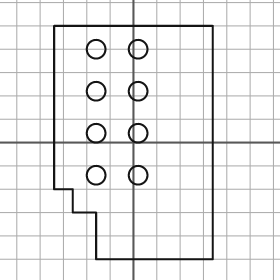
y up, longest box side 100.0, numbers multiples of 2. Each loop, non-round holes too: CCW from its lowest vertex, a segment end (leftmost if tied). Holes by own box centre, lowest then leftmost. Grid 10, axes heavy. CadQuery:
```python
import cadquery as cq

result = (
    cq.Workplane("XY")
    .moveTo(-16.0, -50.0)
    .lineTo(34.0, -50.0)
    .lineTo(34.0, 50.0)
    .lineTo(-34.0, 50.0)
    .lineTo(-34.0, -20.0)
    .lineTo(-26.0, -20.0)
    .lineTo(-26.0, -30.0)
    .lineTo(-16.0, -30.0)
    .close()
    .moveTo(-16.0, -14.0)
    .circle(4.0)
    .moveTo(2.0, -14.0)
    .circle(4.0)
    .moveTo(-16.0, 4.0)
    .circle(4.0)
    .moveTo(2.0, 4.0)
    .circle(4.0)
    .moveTo(-16.0, 22.0)
    .circle(4.0)
    .moveTo(2.0, 22.0)
    .circle(4.0)
    .moveTo(-16.0, 40.0)
    .circle(4.0)
    .moveTo(2.0, 40.0)
    .circle(4.0)
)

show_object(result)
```